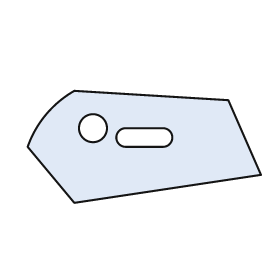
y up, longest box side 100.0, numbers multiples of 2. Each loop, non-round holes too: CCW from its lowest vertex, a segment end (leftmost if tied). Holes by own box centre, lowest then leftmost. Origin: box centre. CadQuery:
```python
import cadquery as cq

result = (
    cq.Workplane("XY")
    .moveTo(-30.0, -24.0)
    .lineTo(50.0, -12.0)
    .lineTo(36.0, 20.0)
    .lineTo(-30.0, 24.0)
    .threePointArc((-42.0, 14.0), (-50.0, 0.0))
    .close()
    .moveTo(-8.0, 0.0)
    .lineTo(8.0, 0.0)
    .threePointArc((12.0, 4.0), (8.0, 8.0))
    .lineTo(-8.0, 8.0)
    .threePointArc((-12.0, 4.0), (-8.0, 0.0))
    .close()
    .moveTo(-22.0, 8.0)
    .circle(6.0)
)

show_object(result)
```